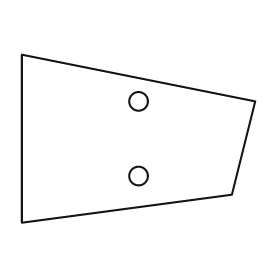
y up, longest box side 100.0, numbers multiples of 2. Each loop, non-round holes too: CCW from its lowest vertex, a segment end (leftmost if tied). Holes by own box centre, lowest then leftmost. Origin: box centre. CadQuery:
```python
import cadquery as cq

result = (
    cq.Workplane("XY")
    .moveTo(-50.0, -36.0)
    .lineTo(40.0, -24.0)
    .lineTo(50.0, 16.0)
    .lineTo(-50.0, 36.0)
    .close()
    .moveTo(0.0, -16.0)
    .circle(4.0)
    .moveTo(0.0, 16.0)
    .circle(4.0)
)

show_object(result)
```